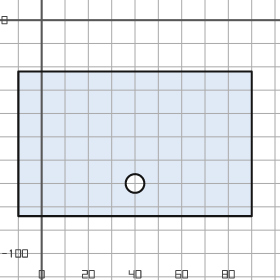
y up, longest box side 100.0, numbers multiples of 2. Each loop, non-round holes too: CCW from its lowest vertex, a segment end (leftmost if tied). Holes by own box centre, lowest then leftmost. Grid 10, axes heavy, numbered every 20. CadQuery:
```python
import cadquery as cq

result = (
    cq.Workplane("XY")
    .moveTo(-10.0, -84.0)
    .lineTo(90.0, -84.0)
    .lineTo(90.0, -22.0)
    .lineTo(-10.0, -22.0)
    .close()
    .moveTo(40.0, -70.0)
    .circle(4.0)
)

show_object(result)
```